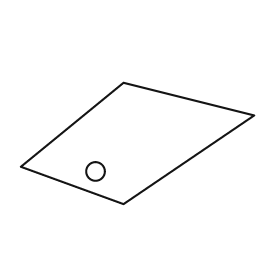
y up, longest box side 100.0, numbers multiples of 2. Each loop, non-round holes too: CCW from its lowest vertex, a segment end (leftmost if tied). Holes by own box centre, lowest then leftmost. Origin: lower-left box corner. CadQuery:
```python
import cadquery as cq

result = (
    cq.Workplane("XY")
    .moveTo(44.0, 0.0)
    .lineTo(100.0, 38.0)
    .lineTo(44.0, 52.0)
    .lineTo(0.0, 16.0)
    .close()
    .moveTo(32.0, 14.0)
    .circle(4.0)
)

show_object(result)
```